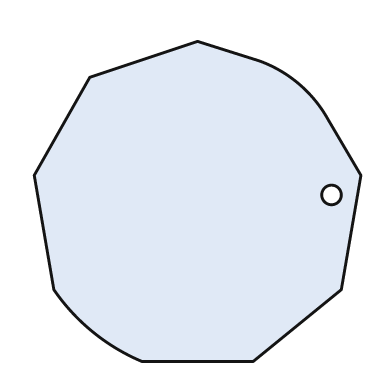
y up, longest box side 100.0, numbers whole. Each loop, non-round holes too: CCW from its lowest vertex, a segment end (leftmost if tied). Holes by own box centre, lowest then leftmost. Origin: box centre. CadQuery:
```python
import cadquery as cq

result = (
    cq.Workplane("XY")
    .moveTo(-17.0, -49.0)
    .lineTo(17.0, -49.0)
    .lineTo(44.0, -27.0)
    .lineTo(50.0, 8.0)
    .lineTo(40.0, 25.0)
    .threePointArc((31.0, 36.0), (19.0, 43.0))
    .lineTo(0.0, 49.0)
    .lineTo(-33.0, 38.0)
    .lineTo(-50.0, 8.0)
    .lineTo(-44.0, -27.0)
    .threePointArc((-32.0, -40.0), (-17.0, -49.0))
    .close()
    .moveTo(41.0, 2.0)
    .circle(3.0)
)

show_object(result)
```